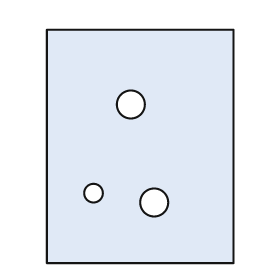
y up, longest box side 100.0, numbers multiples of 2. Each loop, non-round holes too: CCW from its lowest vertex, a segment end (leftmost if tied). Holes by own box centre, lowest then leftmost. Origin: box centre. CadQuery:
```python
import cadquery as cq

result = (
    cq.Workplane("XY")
    .moveTo(-40.0, -50.0)
    .lineTo(40.0, -50.0)
    .lineTo(40.0, 50.0)
    .lineTo(-40.0, 50.0)
    .close()
    .moveTo(6.0, -24.0)
    .circle(6.0)
    .moveTo(-20.0, -20.0)
    .circle(4.0)
    .moveTo(-4.0, 18.0)
    .circle(6.0)
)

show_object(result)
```